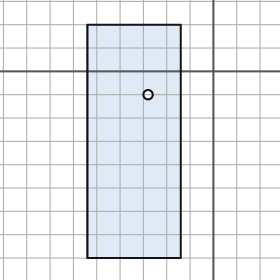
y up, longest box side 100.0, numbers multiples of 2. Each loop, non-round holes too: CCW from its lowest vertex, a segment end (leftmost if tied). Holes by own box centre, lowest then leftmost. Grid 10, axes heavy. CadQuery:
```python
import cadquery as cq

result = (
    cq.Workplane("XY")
    .moveTo(-54.0, -80.0)
    .lineTo(-14.0, -80.0)
    .lineTo(-14.0, 20.0)
    .lineTo(-54.0, 20.0)
    .close()
    .moveTo(-28.0, -10.0)
    .circle(2.0)
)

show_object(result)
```